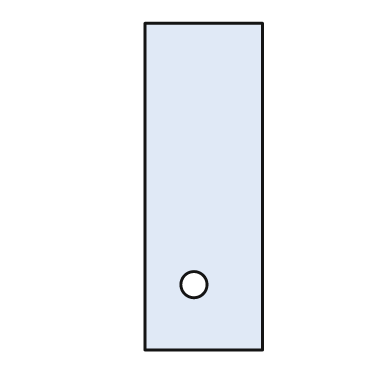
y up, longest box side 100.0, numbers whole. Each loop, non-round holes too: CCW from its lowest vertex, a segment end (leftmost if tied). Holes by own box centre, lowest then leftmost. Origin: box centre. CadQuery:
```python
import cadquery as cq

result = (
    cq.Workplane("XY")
    .moveTo(-18.0, -50.0)
    .lineTo(18.0, -50.0)
    .lineTo(18.0, 50.0)
    .lineTo(-18.0, 50.0)
    .close()
    .moveTo(-3.0, -30.0)
    .circle(4.0)
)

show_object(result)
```